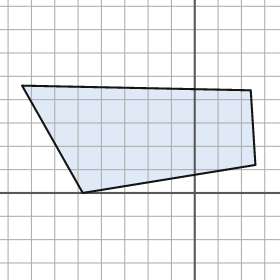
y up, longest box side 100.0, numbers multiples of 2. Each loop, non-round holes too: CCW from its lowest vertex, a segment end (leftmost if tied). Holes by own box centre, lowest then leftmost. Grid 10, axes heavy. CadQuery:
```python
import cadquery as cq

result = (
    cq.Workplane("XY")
    .moveTo(-48.0, 0.0)
    .lineTo(26.0, 12.0)
    .lineTo(24.0, 44.0)
    .lineTo(-74.0, 46.0)
    .close()
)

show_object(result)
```